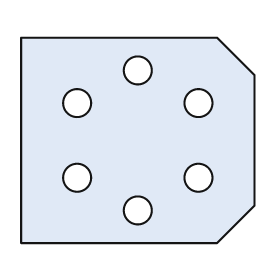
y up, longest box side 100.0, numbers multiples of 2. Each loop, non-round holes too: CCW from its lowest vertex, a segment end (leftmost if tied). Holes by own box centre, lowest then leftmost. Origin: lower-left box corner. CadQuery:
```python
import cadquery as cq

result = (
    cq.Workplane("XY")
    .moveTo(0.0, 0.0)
    .lineTo(84.0, 0.0)
    .lineTo(100.0, 16.0)
    .lineTo(100.0, 72.0)
    .lineTo(84.0, 88.0)
    .lineTo(0.0, 88.0)
    .close()
    .moveTo(50.0, 14.0)
    .circle(6.0)
    .moveTo(24.0, 28.0)
    .circle(6.0)
    .moveTo(76.0, 28.0)
    .circle(6.0)
    .moveTo(24.0, 60.0)
    .circle(6.0)
    .moveTo(76.0, 60.0)
    .circle(6.0)
    .moveTo(50.0, 74.0)
    .circle(6.0)
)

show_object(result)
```